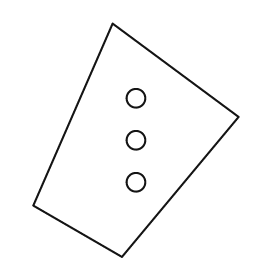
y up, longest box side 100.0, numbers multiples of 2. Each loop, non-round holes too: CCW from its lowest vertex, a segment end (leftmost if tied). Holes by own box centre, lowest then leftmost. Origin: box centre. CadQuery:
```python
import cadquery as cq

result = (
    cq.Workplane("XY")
    .moveTo(-6.0, -50.0)
    .lineTo(44.0, 10.0)
    .lineTo(-10.0, 50.0)
    .lineTo(-44.0, -28.0)
    .close()
    .moveTo(0.0, -18.0)
    .circle(4.0)
    .moveTo(0.0, 0.0)
    .circle(4.0)
    .moveTo(0.0, 18.0)
    .circle(4.0)
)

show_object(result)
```